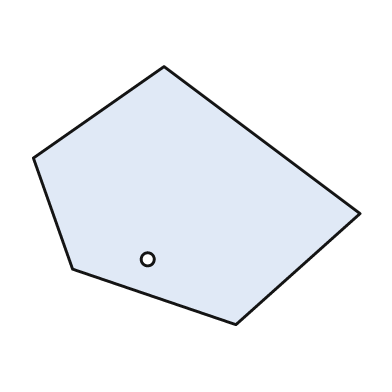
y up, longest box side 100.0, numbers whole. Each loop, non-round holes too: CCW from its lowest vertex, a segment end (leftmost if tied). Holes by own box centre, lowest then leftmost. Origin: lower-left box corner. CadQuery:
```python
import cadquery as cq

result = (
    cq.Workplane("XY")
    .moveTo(62.0, 0.0)
    .lineTo(100.0, 34.0)
    .lineTo(40.0, 79.0)
    .lineTo(0.0, 51.0)
    .lineTo(12.0, 17.0)
    .close()
    .moveTo(35.0, 20.0)
    .circle(2.0)
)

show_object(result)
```